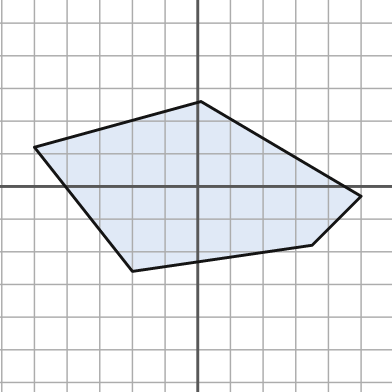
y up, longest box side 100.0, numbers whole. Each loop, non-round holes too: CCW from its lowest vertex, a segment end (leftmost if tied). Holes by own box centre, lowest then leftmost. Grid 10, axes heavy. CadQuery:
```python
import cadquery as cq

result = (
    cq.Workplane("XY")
    .moveTo(-20.0, -26.0)
    .lineTo(35.0, -18.0)
    .lineTo(50.0, -3.0)
    .lineTo(1.0, 26.0)
    .lineTo(-50.0, 12.0)
    .close()
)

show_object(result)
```